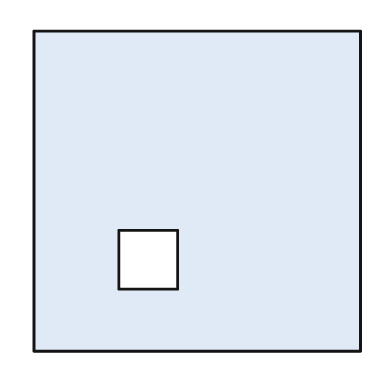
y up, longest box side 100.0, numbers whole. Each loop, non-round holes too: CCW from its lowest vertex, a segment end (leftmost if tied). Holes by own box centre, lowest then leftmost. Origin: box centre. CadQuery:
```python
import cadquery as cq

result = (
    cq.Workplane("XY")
    .moveTo(-50.0, -49.0)
    .lineTo(50.0, -49.0)
    .lineTo(50.0, 49.0)
    .lineTo(-50.0, 49.0)
    .close()
    .moveTo(-24.0, -30.0)
    .lineTo(-6.0, -30.0)
    .lineTo(-6.0, -12.0)
    .lineTo(-24.0, -12.0)
    .close()
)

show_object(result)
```